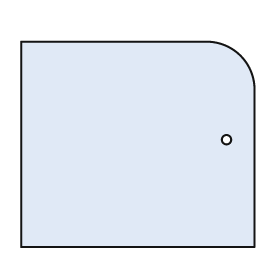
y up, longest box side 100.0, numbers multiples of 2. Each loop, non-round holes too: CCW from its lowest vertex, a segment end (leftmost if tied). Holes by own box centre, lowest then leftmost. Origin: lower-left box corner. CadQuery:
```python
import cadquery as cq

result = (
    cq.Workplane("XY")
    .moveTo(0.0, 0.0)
    .lineTo(100.0, 0.0)
    .lineTo(100.0, 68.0)
    .threePointArc((94.0, 82.0), (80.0, 88.0))
    .lineTo(0.0, 88.0)
    .close()
    .moveTo(88.0, 46.0)
    .circle(2.0)
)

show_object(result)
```